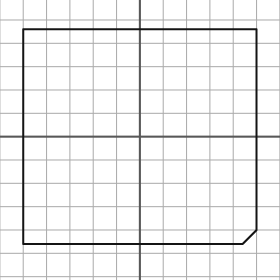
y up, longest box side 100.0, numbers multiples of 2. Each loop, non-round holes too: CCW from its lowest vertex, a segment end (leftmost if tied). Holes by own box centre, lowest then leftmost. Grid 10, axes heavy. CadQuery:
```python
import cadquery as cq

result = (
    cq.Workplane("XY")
    .moveTo(-50.0, -46.0)
    .lineTo(44.0, -46.0)
    .lineTo(50.0, -40.0)
    .lineTo(50.0, 46.0)
    .lineTo(-50.0, 46.0)
    .close()
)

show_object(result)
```